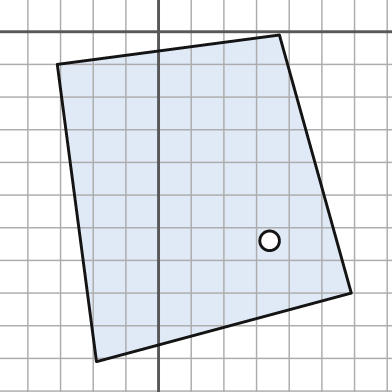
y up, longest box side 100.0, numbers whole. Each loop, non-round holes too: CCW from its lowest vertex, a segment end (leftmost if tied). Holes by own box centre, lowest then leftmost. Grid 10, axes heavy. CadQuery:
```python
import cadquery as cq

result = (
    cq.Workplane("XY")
    .moveTo(-19.0, -101.0)
    .lineTo(59.0, -80.0)
    .lineTo(37.0, -1.0)
    .lineTo(-31.0, -10.0)
    .close()
    .moveTo(34.0, -64.0)
    .circle(3.0)
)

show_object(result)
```